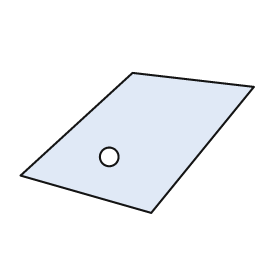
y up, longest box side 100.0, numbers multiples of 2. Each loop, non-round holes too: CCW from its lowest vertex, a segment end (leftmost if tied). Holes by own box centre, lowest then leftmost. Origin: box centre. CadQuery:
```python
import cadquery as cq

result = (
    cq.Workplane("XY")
    .moveTo(6.0, -30.0)
    .lineTo(50.0, 24.0)
    .lineTo(-2.0, 30.0)
    .lineTo(-50.0, -14.0)
    .close()
    .moveTo(-12.0, -6.0)
    .circle(4.0)
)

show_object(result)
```